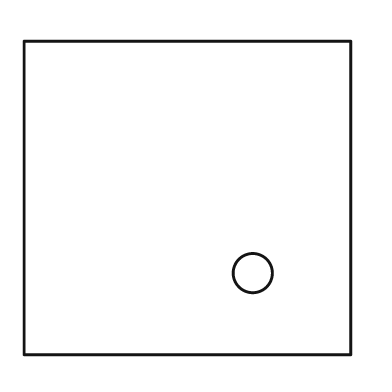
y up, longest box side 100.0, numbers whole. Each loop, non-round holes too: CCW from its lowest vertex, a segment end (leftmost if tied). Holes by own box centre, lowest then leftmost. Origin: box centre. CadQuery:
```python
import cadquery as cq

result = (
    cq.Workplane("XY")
    .moveTo(-50.0, -48.0)
    .lineTo(50.0, -48.0)
    .lineTo(50.0, 48.0)
    .lineTo(-50.0, 48.0)
    .close()
    .moveTo(20.0, -23.0)
    .circle(6.0)
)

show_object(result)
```